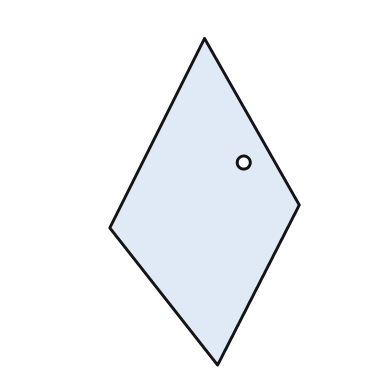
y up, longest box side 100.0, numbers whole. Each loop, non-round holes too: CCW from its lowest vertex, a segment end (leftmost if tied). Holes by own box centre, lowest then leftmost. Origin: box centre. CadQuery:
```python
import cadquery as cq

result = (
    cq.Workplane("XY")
    .moveTo(4.0, -50.0)
    .lineTo(29.0, -1.0)
    .lineTo(0.0, 50.0)
    .lineTo(-29.0, -8.0)
    .close()
    .moveTo(12.0, 12.0)
    .circle(2.0)
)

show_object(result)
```